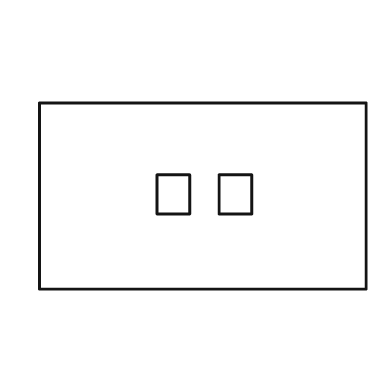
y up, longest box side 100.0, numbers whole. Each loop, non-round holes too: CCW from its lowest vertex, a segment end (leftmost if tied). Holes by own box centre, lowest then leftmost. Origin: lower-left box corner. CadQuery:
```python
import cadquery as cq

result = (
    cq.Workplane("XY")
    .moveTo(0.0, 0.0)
    .lineTo(100.0, 0.0)
    .lineTo(100.0, 57.0)
    .lineTo(0.0, 57.0)
    .close()
    .moveTo(36.0, 23.0)
    .lineTo(46.0, 23.0)
    .lineTo(46.0, 35.0)
    .lineTo(36.0, 35.0)
    .close()
    .moveTo(55.0, 23.0)
    .lineTo(65.0, 23.0)
    .lineTo(65.0, 35.0)
    .lineTo(55.0, 35.0)
    .close()
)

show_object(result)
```